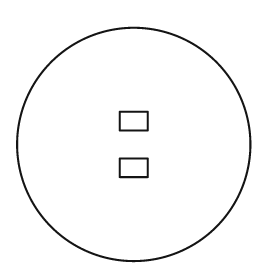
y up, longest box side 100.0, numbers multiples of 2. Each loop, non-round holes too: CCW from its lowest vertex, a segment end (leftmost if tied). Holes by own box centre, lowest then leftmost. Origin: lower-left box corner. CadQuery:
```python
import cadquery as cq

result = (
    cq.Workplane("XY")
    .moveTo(50.0, 50.0)
    .circle(50.0)
    .moveTo(44.0, 36.0)
    .lineTo(56.0, 36.0)
    .lineTo(56.0, 44.0)
    .lineTo(44.0, 44.0)
    .close()
    .moveTo(44.0, 56.0)
    .lineTo(56.0, 56.0)
    .lineTo(56.0, 64.0)
    .lineTo(44.0, 64.0)
    .close()
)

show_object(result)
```